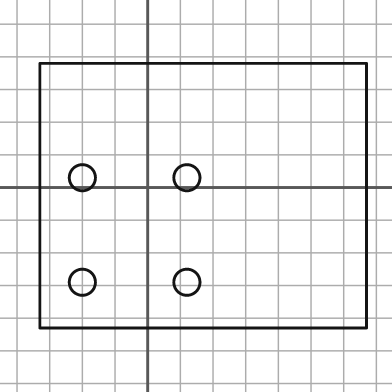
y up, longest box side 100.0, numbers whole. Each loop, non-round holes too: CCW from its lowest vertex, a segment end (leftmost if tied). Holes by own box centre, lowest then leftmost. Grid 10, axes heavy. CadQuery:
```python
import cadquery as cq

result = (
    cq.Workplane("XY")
    .moveTo(-33.0, -43.0)
    .lineTo(67.0, -43.0)
    .lineTo(67.0, 38.0)
    .lineTo(-33.0, 38.0)
    .close()
    .moveTo(-20.0, -29.0)
    .circle(4.0)
    .moveTo(12.0, -29.0)
    .circle(4.0)
    .moveTo(-20.0, 3.0)
    .circle(4.0)
    .moveTo(12.0, 3.0)
    .circle(4.0)
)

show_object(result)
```